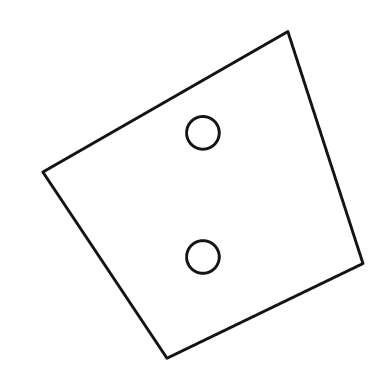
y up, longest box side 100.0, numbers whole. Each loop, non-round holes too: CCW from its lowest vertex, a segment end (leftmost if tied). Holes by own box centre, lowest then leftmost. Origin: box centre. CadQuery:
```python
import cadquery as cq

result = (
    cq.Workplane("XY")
    .moveTo(-11.0, -50.0)
    .lineTo(49.0, -21.0)
    .lineTo(26.0, 50.0)
    .lineTo(-49.0, 7.0)
    .close()
    .moveTo(0.0, -19.0)
    .circle(5.0)
    .moveTo(0.0, 19.0)
    .circle(5.0)
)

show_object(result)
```